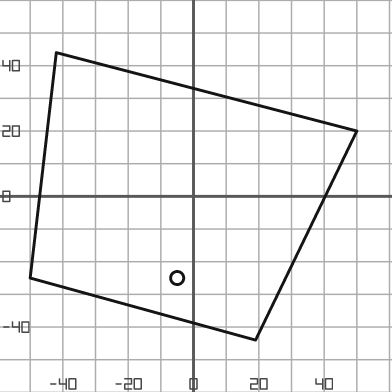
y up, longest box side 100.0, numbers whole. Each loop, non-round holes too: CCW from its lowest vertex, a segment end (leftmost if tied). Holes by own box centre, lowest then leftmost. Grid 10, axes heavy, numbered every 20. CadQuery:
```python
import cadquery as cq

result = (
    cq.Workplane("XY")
    .moveTo(19.0, -44.0)
    .lineTo(50.0, 20.0)
    .lineTo(-42.0, 44.0)
    .lineTo(-50.0, -25.0)
    .close()
    .moveTo(-5.0, -25.0)
    .circle(2.0)
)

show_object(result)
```